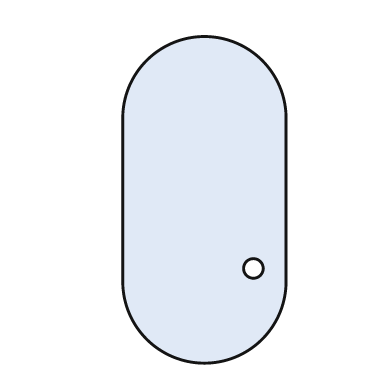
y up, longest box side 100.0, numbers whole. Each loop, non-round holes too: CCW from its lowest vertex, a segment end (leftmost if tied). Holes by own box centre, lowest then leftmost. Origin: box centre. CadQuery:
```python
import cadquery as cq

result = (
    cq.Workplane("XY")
    .moveTo(-25.0, -25.0)
    .threePointArc((0.0, -50.0), (25.0, -25.0))
    .lineTo(25.0, 25.0)
    .threePointArc((0.0, 50.0), (-25.0, 25.0))
    .close()
    .moveTo(15.0, -21.0)
    .circle(3.0)
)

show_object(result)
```